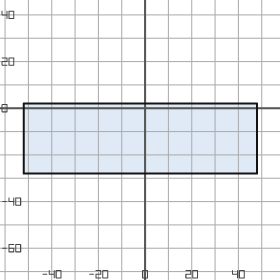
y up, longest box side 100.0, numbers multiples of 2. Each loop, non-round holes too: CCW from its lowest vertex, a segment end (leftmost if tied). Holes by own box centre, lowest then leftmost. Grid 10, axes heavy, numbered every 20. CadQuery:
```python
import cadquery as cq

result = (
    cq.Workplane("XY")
    .moveTo(-52.0, -28.0)
    .lineTo(48.0, -28.0)
    .lineTo(48.0, 2.0)
    .lineTo(-52.0, 2.0)
    .close()
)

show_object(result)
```